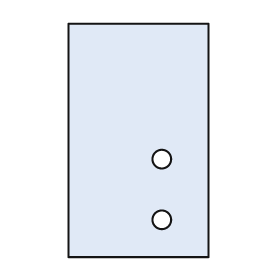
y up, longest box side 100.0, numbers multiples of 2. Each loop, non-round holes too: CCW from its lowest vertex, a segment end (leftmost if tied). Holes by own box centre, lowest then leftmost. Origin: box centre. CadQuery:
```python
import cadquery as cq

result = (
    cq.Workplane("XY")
    .moveTo(-30.0, -50.0)
    .lineTo(30.0, -50.0)
    .lineTo(30.0, 50.0)
    .lineTo(-30.0, 50.0)
    .close()
    .moveTo(10.0, -34.0)
    .circle(4.0)
    .moveTo(10.0, -8.0)
    .circle(4.0)
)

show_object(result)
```